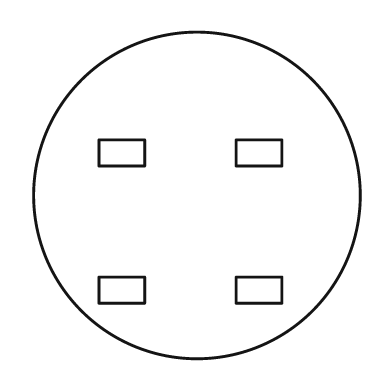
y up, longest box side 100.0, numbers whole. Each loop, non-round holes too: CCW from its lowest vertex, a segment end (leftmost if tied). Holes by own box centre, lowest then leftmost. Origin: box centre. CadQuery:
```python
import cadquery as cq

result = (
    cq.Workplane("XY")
    .moveTo(0.0, 0.0)
    .circle(50.0)
    .moveTo(-30.0, -33.0)
    .lineTo(-16.0, -33.0)
    .lineTo(-16.0, -25.0)
    .lineTo(-30.0, -25.0)
    .close()
    .moveTo(12.0, -33.0)
    .lineTo(26.0, -33.0)
    .lineTo(26.0, -25.0)
    .lineTo(12.0, -25.0)
    .close()
    .moveTo(-30.0, 9.0)
    .lineTo(-16.0, 9.0)
    .lineTo(-16.0, 17.0)
    .lineTo(-30.0, 17.0)
    .close()
    .moveTo(12.0, 9.0)
    .lineTo(26.0, 9.0)
    .lineTo(26.0, 17.0)
    .lineTo(12.0, 17.0)
    .close()
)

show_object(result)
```